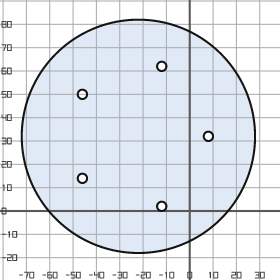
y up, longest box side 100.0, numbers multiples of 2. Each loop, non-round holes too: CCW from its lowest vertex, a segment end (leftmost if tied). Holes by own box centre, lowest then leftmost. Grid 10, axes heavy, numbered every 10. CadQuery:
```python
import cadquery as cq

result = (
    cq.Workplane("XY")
    .moveTo(-22.0, 32.0)
    .circle(50.0)
    .moveTo(-12.0, 2.0)
    .circle(2.0)
    .moveTo(-46.0, 14.0)
    .circle(2.0)
    .moveTo(8.0, 32.0)
    .circle(2.0)
    .moveTo(-46.0, 50.0)
    .circle(2.0)
    .moveTo(-12.0, 62.0)
    .circle(2.0)
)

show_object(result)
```